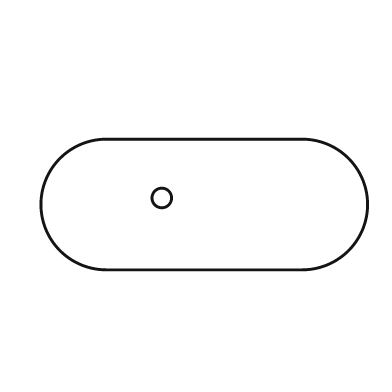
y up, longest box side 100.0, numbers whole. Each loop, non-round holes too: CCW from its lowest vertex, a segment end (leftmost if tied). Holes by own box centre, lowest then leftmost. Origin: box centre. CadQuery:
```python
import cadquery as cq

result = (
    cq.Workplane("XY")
    .moveTo(-30.0, -20.0)
    .lineTo(30.0, -20.0)
    .threePointArc((50.0, 0.0), (30.0, 20.0))
    .lineTo(-30.0, 20.0)
    .threePointArc((-50.0, 0.0), (-30.0, -20.0))
    .close()
    .moveTo(-13.0, 2.0)
    .circle(3.0)
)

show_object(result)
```